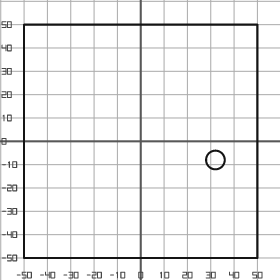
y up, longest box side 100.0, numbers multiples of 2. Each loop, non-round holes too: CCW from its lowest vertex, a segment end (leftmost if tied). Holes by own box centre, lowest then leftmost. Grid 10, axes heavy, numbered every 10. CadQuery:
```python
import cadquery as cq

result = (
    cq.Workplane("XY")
    .moveTo(-50.0, -50.0)
    .lineTo(50.0, -50.0)
    .lineTo(50.0, 50.0)
    .lineTo(-50.0, 50.0)
    .close()
    .moveTo(32.0, -8.0)
    .circle(4.0)
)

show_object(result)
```